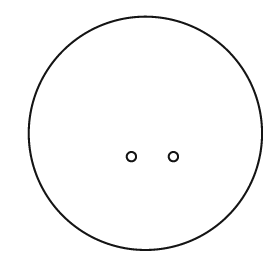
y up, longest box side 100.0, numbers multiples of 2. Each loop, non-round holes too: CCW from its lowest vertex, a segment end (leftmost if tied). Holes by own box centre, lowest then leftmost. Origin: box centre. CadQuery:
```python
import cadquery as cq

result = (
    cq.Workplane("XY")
    .moveTo(0.0, 0.0)
    .circle(50.0)
    .moveTo(-6.0, -10.0)
    .circle(2.0)
    .moveTo(12.0, -10.0)
    .circle(2.0)
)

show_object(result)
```